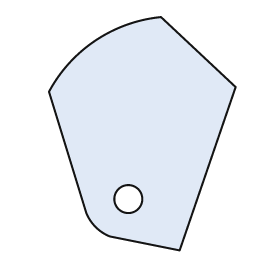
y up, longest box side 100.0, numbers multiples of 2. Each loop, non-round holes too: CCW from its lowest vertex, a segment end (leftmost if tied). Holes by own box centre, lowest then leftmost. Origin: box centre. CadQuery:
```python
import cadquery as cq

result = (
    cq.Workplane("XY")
    .moveTo(16.0, -50.0)
    .lineTo(40.0, 20.0)
    .lineTo(8.0, 50.0)
    .threePointArc((-20.0, 40.0), (-40.0, 18.0))
    .lineTo(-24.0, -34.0)
    .threePointArc((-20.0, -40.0), (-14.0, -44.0))
    .close()
    .moveTo(-6.0, -28.0)
    .circle(6.0)
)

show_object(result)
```